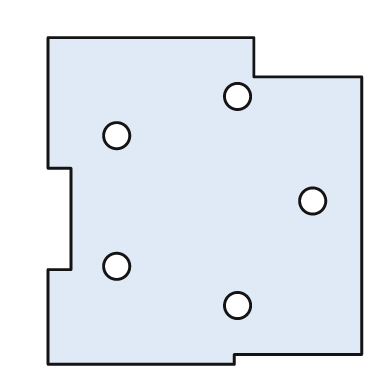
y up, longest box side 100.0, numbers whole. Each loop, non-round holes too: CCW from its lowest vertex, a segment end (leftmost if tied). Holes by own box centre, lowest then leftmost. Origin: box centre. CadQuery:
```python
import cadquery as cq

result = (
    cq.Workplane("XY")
    .moveTo(-48.0, -50.0)
    .lineTo(9.0, -50.0)
    .lineTo(9.0, -47.0)
    .lineTo(48.0, -47.0)
    .lineTo(48.0, 38.0)
    .lineTo(15.0, 38.0)
    .lineTo(15.0, 50.0)
    .lineTo(-48.0, 50.0)
    .lineTo(-48.0, 10.0)
    .lineTo(-41.0, 10.0)
    .lineTo(-41.0, -21.0)
    .lineTo(-48.0, -21.0)
    .close()
    .moveTo(10.0, -32.0)
    .circle(4.0)
    .moveTo(-27.0, -20.0)
    .circle(4.0)
    .moveTo(33.0, 0.0)
    .circle(4.0)
    .moveTo(-27.0, 20.0)
    .circle(4.0)
    .moveTo(10.0, 32.0)
    .circle(4.0)
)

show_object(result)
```